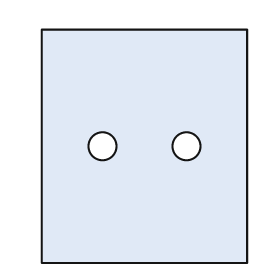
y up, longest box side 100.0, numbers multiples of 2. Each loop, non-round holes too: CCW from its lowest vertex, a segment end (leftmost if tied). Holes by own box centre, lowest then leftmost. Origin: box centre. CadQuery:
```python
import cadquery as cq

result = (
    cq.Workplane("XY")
    .moveTo(-44.0, -50.0)
    .lineTo(44.0, -50.0)
    .lineTo(44.0, 50.0)
    .lineTo(-44.0, 50.0)
    .close()
    .moveTo(-18.0, 0.0)
    .circle(6.0)
    .moveTo(18.0, 0.0)
    .circle(6.0)
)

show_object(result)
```